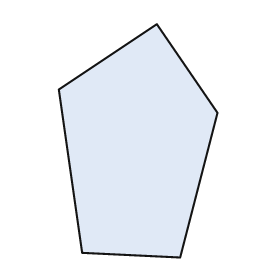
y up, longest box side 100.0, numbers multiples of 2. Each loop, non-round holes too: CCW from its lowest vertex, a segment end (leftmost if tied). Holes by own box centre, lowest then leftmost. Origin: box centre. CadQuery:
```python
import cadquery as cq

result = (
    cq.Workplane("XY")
    .moveTo(18.0, -50.0)
    .lineTo(34.0, 12.0)
    .lineTo(8.0, 50.0)
    .lineTo(-34.0, 22.0)
    .lineTo(-24.0, -48.0)
    .close()
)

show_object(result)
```